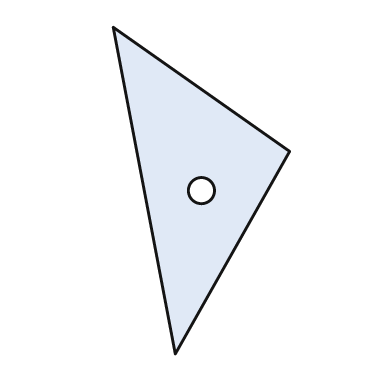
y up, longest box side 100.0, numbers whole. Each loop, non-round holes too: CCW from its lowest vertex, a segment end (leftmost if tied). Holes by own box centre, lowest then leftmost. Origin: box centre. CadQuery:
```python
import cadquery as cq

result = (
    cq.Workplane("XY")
    .moveTo(-8.0, -50.0)
    .lineTo(27.0, 12.0)
    .lineTo(-27.0, 50.0)
    .close()
    .moveTo(0.0, 0.0)
    .circle(4.0)
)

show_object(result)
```